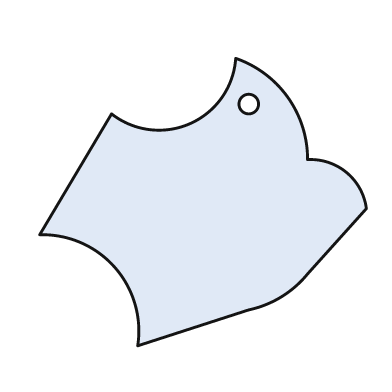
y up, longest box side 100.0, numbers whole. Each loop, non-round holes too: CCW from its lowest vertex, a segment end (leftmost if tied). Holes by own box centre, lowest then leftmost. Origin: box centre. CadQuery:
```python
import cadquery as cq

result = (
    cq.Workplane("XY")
    .moveTo(-20.0, -44.0)
    .lineTo(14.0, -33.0)
    .threePointArc((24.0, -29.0), (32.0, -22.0))
    .lineTo(50.0, -2.0)
    .threePointArc((44.0, 9.0), (32.0, 13.0))
    .threePointArc((26.0, 32.0), (10.0, 44.0))
    .threePointArc((-4.0, 24.0), (-28.0, 27.0))
    .lineTo(-50.0, -10.0)
    .threePointArc((-27.0, -20.0), (-20.0, -44.0))
    .close()
    .moveTo(14.0, 30.0)
    .circle(3.0)
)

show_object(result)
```